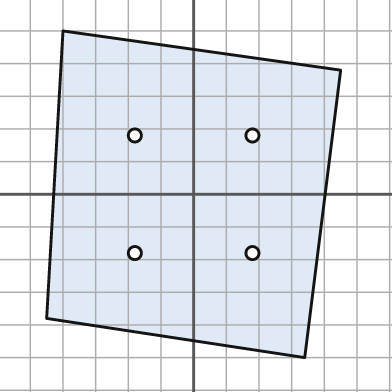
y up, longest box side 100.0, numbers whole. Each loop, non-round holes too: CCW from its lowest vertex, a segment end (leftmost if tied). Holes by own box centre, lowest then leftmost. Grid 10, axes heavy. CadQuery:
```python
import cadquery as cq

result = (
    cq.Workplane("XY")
    .moveTo(34.0, -50.0)
    .lineTo(45.0, 38.0)
    .lineTo(-40.0, 50.0)
    .lineTo(-45.0, -38.0)
    .close()
    .moveTo(-18.0, -18.0)
    .circle(2.0)
    .moveTo(18.0, -18.0)
    .circle(2.0)
    .moveTo(-18.0, 18.0)
    .circle(2.0)
    .moveTo(18.0, 18.0)
    .circle(2.0)
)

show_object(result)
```